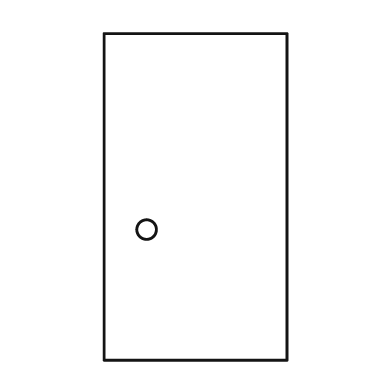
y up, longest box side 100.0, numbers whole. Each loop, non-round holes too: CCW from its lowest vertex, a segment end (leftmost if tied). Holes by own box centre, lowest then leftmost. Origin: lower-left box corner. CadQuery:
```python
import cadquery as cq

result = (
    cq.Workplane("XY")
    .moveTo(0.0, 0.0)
    .lineTo(56.0, 0.0)
    .lineTo(56.0, 100.0)
    .lineTo(0.0, 100.0)
    .close()
    .moveTo(13.0, 40.0)
    .circle(3.0)
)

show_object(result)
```